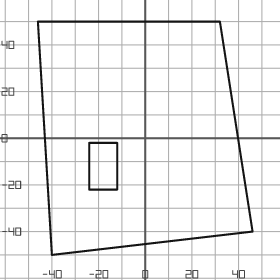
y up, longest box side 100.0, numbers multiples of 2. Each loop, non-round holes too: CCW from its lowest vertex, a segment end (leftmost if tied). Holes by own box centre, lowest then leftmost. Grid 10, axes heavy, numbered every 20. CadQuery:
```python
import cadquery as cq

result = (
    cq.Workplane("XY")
    .moveTo(-40.0, -50.0)
    .lineTo(46.0, -40.0)
    .lineTo(32.0, 50.0)
    .lineTo(-46.0, 50.0)
    .close()
    .moveTo(-24.0, -22.0)
    .lineTo(-12.0, -22.0)
    .lineTo(-12.0, -2.0)
    .lineTo(-24.0, -2.0)
    .close()
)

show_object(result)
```